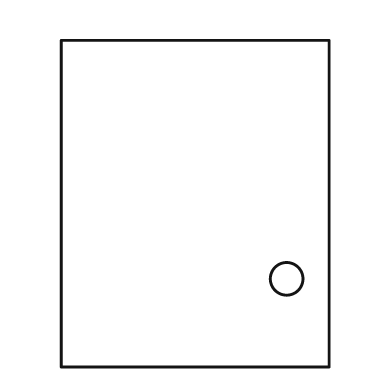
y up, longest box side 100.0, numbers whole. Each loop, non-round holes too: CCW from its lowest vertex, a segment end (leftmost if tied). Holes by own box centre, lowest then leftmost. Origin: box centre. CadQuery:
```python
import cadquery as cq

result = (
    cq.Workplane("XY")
    .moveTo(-41.0, -50.0)
    .lineTo(41.0, -50.0)
    .lineTo(41.0, 50.0)
    .lineTo(-41.0, 50.0)
    .close()
    .moveTo(28.0, -23.0)
    .circle(5.0)
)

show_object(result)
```